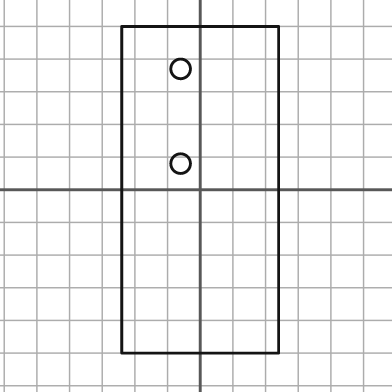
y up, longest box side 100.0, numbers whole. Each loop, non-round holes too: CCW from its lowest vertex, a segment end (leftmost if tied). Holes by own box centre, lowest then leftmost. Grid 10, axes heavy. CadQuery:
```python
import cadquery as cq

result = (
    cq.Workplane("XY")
    .moveTo(-24.0, -50.0)
    .lineTo(24.0, -50.0)
    .lineTo(24.0, 50.0)
    .lineTo(-24.0, 50.0)
    .close()
    .moveTo(-6.0, 8.0)
    .circle(3.0)
    .moveTo(-6.0, 37.0)
    .circle(3.0)
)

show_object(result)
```